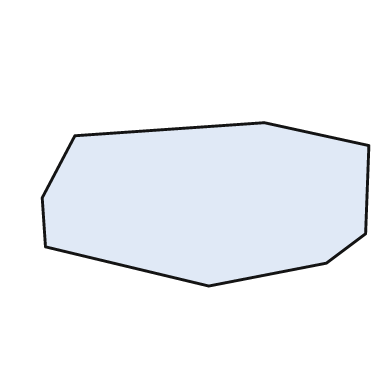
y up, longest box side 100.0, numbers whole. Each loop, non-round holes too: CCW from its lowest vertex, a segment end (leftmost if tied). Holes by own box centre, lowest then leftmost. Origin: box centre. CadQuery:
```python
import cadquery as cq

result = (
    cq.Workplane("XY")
    .moveTo(1.0, -25.0)
    .lineTo(37.0, -18.0)
    .lineTo(49.0, -9.0)
    .lineTo(50.0, 18.0)
    .lineTo(18.0, 25.0)
    .lineTo(-40.0, 21.0)
    .lineTo(-50.0, 2.0)
    .lineTo(-49.0, -13.0)
    .close()
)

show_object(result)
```